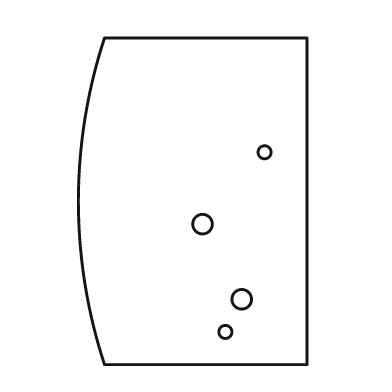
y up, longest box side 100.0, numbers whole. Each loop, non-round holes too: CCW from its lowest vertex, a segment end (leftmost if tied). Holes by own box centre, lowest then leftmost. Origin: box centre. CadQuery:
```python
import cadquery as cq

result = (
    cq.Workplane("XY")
    .moveTo(-27.0, -50.0)
    .lineTo(35.0, -50.0)
    .lineTo(35.0, 50.0)
    .lineTo(-27.0, 50.0)
    .threePointArc((-35.0, 0.0), (-27.0, -50.0))
    .close()
    .moveTo(10.0, -40.0)
    .circle(2.0)
    .moveTo(15.0, -30.0)
    .circle(3.0)
    .moveTo(3.0, -7.0)
    .circle(3.0)
    .moveTo(22.0, 15.0)
    .circle(2.0)
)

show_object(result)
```